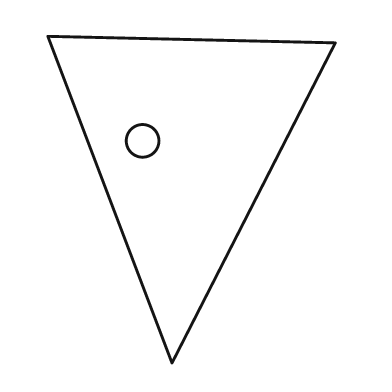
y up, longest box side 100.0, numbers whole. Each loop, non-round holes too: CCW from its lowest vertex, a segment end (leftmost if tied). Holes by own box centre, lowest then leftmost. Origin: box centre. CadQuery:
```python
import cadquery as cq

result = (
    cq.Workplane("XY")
    .moveTo(-6.0, -50.0)
    .lineTo(44.0, 48.0)
    .lineTo(-44.0, 50.0)
    .close()
    .moveTo(-15.0, 18.0)
    .circle(5.0)
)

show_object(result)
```